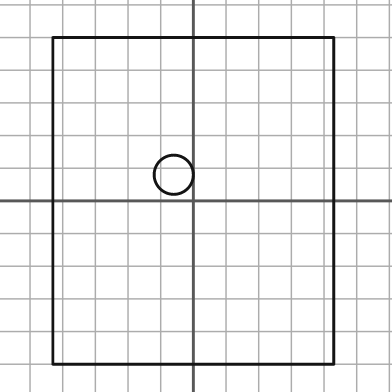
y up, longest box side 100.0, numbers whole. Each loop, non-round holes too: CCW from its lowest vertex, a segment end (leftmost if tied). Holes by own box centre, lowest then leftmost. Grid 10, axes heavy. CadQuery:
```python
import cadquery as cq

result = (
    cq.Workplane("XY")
    .moveTo(-43.0, -50.0)
    .lineTo(43.0, -50.0)
    .lineTo(43.0, 50.0)
    .lineTo(-43.0, 50.0)
    .close()
    .moveTo(-6.0, 8.0)
    .circle(6.0)
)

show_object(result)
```